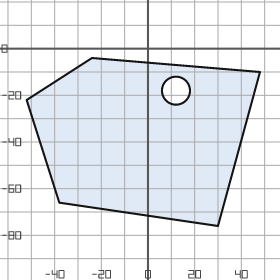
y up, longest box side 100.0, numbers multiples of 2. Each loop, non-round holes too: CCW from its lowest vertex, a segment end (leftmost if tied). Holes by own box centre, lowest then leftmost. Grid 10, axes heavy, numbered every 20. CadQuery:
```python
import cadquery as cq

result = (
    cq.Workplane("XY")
    .moveTo(30.0, -76.0)
    .lineTo(48.0, -10.0)
    .lineTo(-24.0, -4.0)
    .lineTo(-52.0, -22.0)
    .lineTo(-38.0, -66.0)
    .close()
    .moveTo(12.0, -18.0)
    .circle(6.0)
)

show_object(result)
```